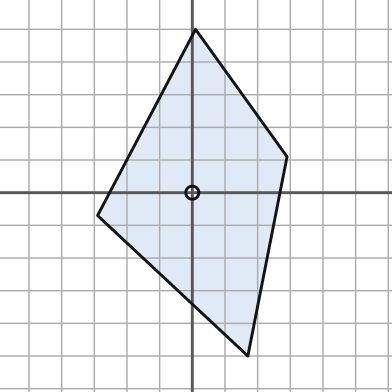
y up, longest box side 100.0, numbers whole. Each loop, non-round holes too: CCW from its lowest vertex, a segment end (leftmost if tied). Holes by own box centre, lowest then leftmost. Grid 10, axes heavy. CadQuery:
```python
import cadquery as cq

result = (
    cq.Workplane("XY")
    .moveTo(17.0, -50.0)
    .lineTo(29.0, 11.0)
    .lineTo(1.0, 50.0)
    .lineTo(-29.0, -7.0)
    .close()
    .moveTo(0.0, 0.0)
    .circle(2.0)
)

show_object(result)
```